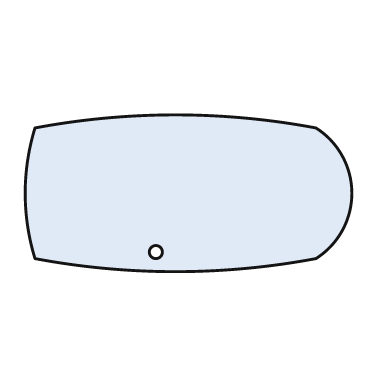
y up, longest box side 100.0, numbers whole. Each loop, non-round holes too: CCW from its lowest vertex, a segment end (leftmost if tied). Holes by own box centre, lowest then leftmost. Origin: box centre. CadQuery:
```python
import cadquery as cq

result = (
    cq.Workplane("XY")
    .moveTo(-47.0, -20.0)
    .threePointArc((-4.0, -24.0), (39.0, -20.0))
    .threePointArc((50.0, 0.0), (39.0, 20.0))
    .threePointArc((-4.0, 24.0), (-47.0, 20.0))
    .threePointArc((-50.0, 0.0), (-47.0, -20.0))
    .close()
    .moveTo(-10.0, -18.0)
    .circle(2.0)
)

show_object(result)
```